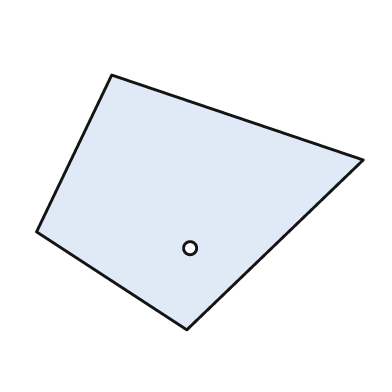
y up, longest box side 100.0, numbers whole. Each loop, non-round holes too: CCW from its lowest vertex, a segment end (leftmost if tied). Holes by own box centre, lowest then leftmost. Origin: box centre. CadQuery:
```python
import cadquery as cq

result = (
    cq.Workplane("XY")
    .moveTo(-4.0, -39.0)
    .lineTo(50.0, 13.0)
    .lineTo(-27.0, 39.0)
    .lineTo(-50.0, -9.0)
    .close()
    .moveTo(-3.0, -14.0)
    .circle(2.0)
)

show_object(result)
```